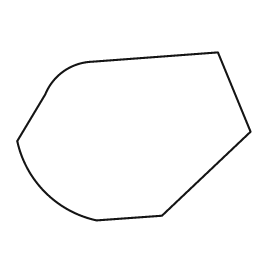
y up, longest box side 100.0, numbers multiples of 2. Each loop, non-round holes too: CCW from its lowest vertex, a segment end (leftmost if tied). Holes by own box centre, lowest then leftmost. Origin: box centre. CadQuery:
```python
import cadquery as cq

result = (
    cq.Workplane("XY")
    .moveTo(-16.0, -36.0)
    .lineTo(12.0, -34.0)
    .lineTo(50.0, 2.0)
    .lineTo(36.0, 36.0)
    .lineTo(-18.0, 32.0)
    .threePointArc((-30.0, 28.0), (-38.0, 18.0))
    .lineTo(-50.0, -2.0)
    .threePointArc((-38.0, -24.0), (-16.0, -36.0))
    .close()
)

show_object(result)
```